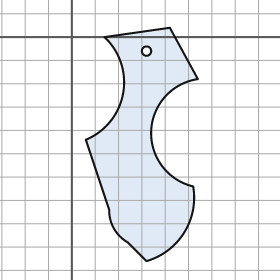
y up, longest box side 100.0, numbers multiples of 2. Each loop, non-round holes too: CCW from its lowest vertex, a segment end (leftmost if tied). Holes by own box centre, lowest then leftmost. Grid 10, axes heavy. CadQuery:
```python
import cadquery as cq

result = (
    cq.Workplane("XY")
    .moveTo(32.0, -96.0)
    .threePointArc((48.0, -84.0), (52.0, -64.0))
    .threePointArc((34.0, -40.0), (54.0, -18.0))
    .lineTo(42.0, 4.0)
    .lineTo(14.0, 0.0)
    .threePointArc((22.0, -24.0), (6.0, -44.0))
    .lineTo(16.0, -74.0)
    .threePointArc((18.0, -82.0), (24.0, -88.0))
    .close()
    .moveTo(32.0, -6.0)
    .circle(2.0)
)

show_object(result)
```